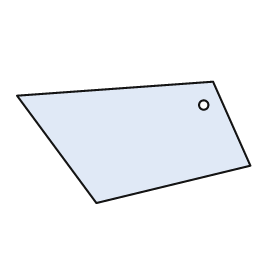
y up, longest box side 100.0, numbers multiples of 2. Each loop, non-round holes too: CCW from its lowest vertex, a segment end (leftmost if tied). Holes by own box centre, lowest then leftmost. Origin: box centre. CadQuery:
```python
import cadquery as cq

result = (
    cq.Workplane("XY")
    .moveTo(-16.0, -26.0)
    .lineTo(50.0, -10.0)
    .lineTo(34.0, 26.0)
    .lineTo(-50.0, 20.0)
    .close()
    .moveTo(30.0, 16.0)
    .circle(2.0)
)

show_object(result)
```